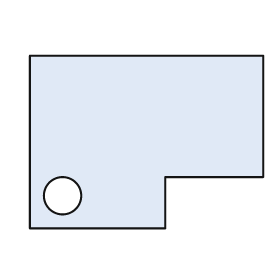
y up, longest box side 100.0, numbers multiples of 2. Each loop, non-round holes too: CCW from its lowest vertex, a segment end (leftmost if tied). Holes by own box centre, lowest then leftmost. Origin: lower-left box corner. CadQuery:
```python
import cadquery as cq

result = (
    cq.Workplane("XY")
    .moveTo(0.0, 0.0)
    .lineTo(58.0, 0.0)
    .lineTo(58.0, 22.0)
    .lineTo(100.0, 22.0)
    .lineTo(100.0, 74.0)
    .lineTo(0.0, 74.0)
    .close()
    .moveTo(14.0, 14.0)
    .circle(8.0)
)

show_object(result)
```